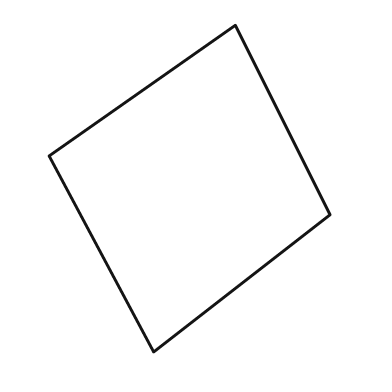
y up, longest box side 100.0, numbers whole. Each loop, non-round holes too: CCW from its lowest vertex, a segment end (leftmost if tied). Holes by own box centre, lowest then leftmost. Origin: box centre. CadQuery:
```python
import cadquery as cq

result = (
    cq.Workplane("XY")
    .moveTo(-11.0, -50.0)
    .lineTo(43.0, -8.0)
    .lineTo(14.0, 50.0)
    .lineTo(-43.0, 10.0)
    .close()
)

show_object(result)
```